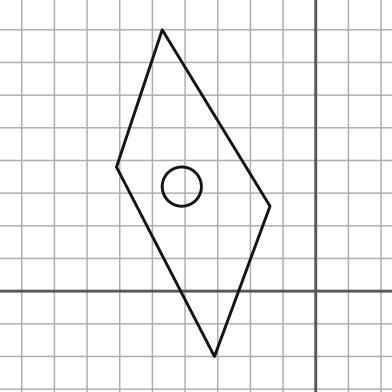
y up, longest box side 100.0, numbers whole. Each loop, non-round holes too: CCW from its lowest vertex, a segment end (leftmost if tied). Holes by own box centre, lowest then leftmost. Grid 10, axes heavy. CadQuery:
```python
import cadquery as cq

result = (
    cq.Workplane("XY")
    .moveTo(-31.0, -20.0)
    .lineTo(-14.0, 26.0)
    .lineTo(-47.0, 80.0)
    .lineTo(-61.0, 38.0)
    .close()
    .moveTo(-41.0, 32.0)
    .circle(6.0)
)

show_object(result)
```